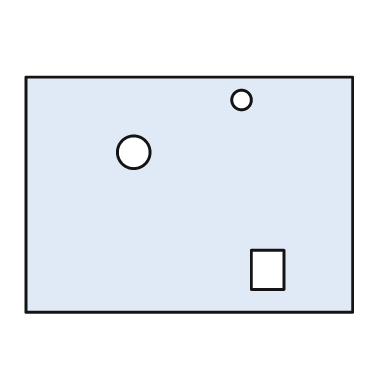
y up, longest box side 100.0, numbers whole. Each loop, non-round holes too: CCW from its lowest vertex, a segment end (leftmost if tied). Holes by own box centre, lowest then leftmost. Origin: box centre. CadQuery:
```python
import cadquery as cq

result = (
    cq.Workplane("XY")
    .moveTo(-50.0, -36.0)
    .lineTo(50.0, -36.0)
    .lineTo(50.0, 36.0)
    .lineTo(-50.0, 36.0)
    .close()
    .moveTo(19.0, -29.0)
    .lineTo(29.0, -29.0)
    .lineTo(29.0, -17.0)
    .lineTo(19.0, -17.0)
    .close()
    .moveTo(-17.0, 13.0)
    .circle(5.0)
    .moveTo(16.0, 29.0)
    .circle(3.0)
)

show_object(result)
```